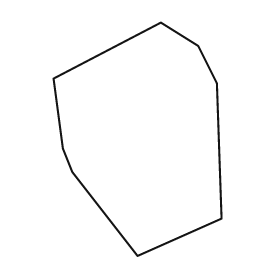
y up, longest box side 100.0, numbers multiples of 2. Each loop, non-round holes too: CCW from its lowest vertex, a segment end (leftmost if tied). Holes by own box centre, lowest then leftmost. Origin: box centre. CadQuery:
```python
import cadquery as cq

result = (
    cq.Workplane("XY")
    .moveTo(0.0, -50.0)
    .lineTo(36.0, -34.0)
    .lineTo(34.0, 24.0)
    .lineTo(26.0, 40.0)
    .lineTo(10.0, 50.0)
    .lineTo(-36.0, 26.0)
    .lineTo(-32.0, -4.0)
    .lineTo(-28.0, -14.0)
    .close()
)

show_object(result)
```